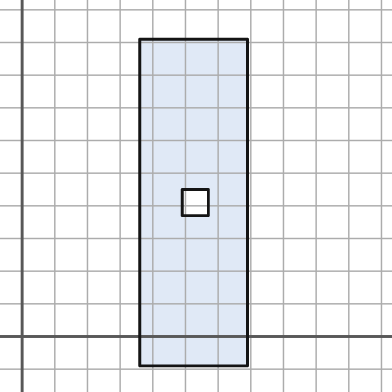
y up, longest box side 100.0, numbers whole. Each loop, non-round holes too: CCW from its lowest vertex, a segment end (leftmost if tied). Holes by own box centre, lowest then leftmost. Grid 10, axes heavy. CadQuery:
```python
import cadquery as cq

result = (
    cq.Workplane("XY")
    .moveTo(36.0, -9.0)
    .lineTo(69.0, -9.0)
    .lineTo(69.0, 91.0)
    .lineTo(36.0, 91.0)
    .close()
    .moveTo(49.0, 37.0)
    .lineTo(57.0, 37.0)
    .lineTo(57.0, 45.0)
    .lineTo(49.0, 45.0)
    .close()
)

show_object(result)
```